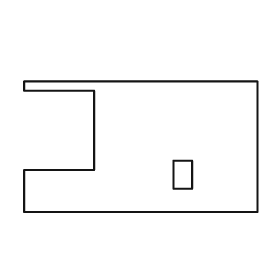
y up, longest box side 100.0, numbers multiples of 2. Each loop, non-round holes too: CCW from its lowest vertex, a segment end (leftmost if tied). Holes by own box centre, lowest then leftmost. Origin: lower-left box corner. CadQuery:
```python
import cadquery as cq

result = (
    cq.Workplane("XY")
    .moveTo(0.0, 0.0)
    .lineTo(100.0, 0.0)
    .lineTo(100.0, 56.0)
    .lineTo(0.0, 56.0)
    .lineTo(0.0, 52.0)
    .lineTo(30.0, 52.0)
    .lineTo(30.0, 18.0)
    .lineTo(0.0, 18.0)
    .close()
    .moveTo(64.0, 10.0)
    .lineTo(72.0, 10.0)
    .lineTo(72.0, 22.0)
    .lineTo(64.0, 22.0)
    .close()
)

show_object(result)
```